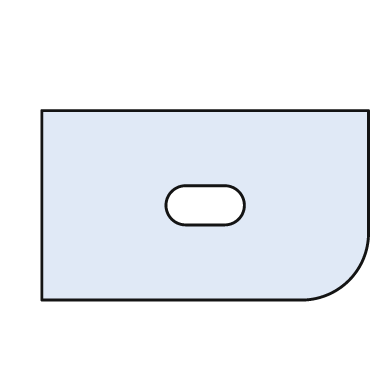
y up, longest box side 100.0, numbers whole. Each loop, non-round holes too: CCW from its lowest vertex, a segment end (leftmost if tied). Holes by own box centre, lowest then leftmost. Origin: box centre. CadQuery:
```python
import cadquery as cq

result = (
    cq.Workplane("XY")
    .moveTo(-50.0, -29.0)
    .lineTo(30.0, -29.0)
    .threePointArc((44.0, -23.0), (50.0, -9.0))
    .lineTo(50.0, 29.0)
    .lineTo(-50.0, 29.0)
    .close()
    .moveTo(-6.0, -6.0)
    .lineTo(6.0, -6.0)
    .threePointArc((12.0, 0.0), (6.0, 6.0))
    .lineTo(-6.0, 6.0)
    .threePointArc((-12.0, 0.0), (-6.0, -6.0))
    .close()
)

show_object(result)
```